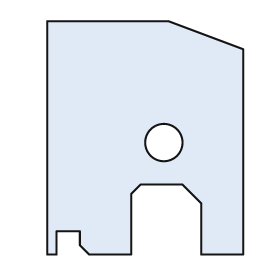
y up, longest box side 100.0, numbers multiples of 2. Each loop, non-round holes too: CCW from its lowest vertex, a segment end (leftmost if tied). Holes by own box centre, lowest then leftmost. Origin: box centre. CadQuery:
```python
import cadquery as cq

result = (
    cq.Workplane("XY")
    .moveTo(-42.0, -50.0)
    .lineTo(-38.0, -50.0)
    .lineTo(-38.0, -40.0)
    .lineTo(-28.0, -40.0)
    .lineTo(-28.0, -46.0)
    .lineTo(-24.0, -50.0)
    .lineTo(-6.0, -50.0)
    .lineTo(-6.0, -24.0)
    .lineTo(-2.0, -20.0)
    .lineTo(16.0, -20.0)
    .lineTo(24.0, -28.0)
    .lineTo(24.0, -50.0)
    .lineTo(42.0, -50.0)
    .lineTo(42.0, 38.0)
    .lineTo(10.0, 50.0)
    .lineTo(-42.0, 50.0)
    .close()
    .moveTo(8.0, -2.0)
    .circle(8.0)
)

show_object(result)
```